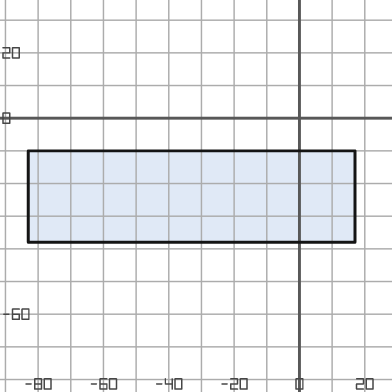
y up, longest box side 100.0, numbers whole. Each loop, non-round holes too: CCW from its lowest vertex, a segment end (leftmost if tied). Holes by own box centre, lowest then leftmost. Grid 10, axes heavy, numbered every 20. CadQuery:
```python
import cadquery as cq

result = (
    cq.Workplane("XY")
    .moveTo(-83.0, -38.0)
    .lineTo(17.0, -38.0)
    .lineTo(17.0, -10.0)
    .lineTo(-83.0, -10.0)
    .close()
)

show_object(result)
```